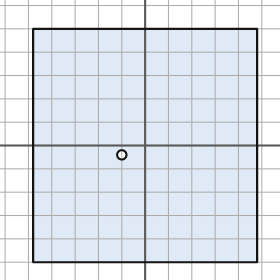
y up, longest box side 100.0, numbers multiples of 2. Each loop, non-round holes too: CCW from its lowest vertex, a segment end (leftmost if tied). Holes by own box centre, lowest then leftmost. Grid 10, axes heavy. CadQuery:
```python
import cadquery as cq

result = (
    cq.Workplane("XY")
    .moveTo(-48.0, -50.0)
    .lineTo(48.0, -50.0)
    .lineTo(48.0, 50.0)
    .lineTo(-48.0, 50.0)
    .close()
    .moveTo(-10.0, -4.0)
    .circle(2.0)
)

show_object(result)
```